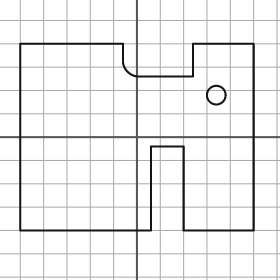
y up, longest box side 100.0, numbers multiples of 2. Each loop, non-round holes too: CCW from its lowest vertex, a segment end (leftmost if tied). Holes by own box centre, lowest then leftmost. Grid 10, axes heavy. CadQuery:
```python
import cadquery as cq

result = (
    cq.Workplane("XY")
    .moveTo(-50.0, -40.0)
    .lineTo(6.0, -40.0)
    .lineTo(6.0, -4.0)
    .lineTo(20.0, -4.0)
    .lineTo(20.0, -40.0)
    .lineTo(50.0, -40.0)
    .lineTo(50.0, 40.0)
    .lineTo(24.0, 40.0)
    .lineTo(24.0, 26.0)
    .lineTo(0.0, 26.0)
    .threePointArc((-4.0, 28.0), (-6.0, 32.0))
    .lineTo(-6.0, 40.0)
    .lineTo(-50.0, 40.0)
    .close()
    .moveTo(34.0, 18.0)
    .circle(4.0)
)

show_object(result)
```